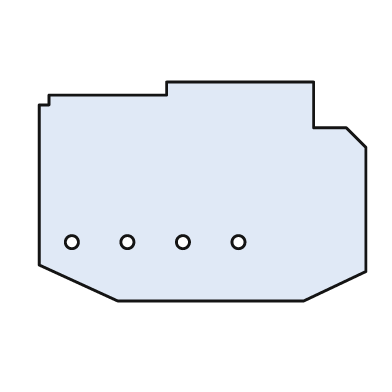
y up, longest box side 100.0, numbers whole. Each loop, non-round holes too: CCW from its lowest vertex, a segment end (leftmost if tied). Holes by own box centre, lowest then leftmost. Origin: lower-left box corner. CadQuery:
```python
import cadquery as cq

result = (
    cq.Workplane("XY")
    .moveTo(24.0, 0.0)
    .lineTo(81.0, 0.0)
    .lineTo(100.0, 9.0)
    .lineTo(100.0, 47.0)
    .lineTo(94.0, 53.0)
    .lineTo(84.0, 53.0)
    .lineTo(84.0, 67.0)
    .lineTo(39.0, 67.0)
    .lineTo(39.0, 63.0)
    .lineTo(3.0, 63.0)
    .lineTo(3.0, 60.0)
    .lineTo(0.0, 60.0)
    .lineTo(0.0, 11.0)
    .close()
    .moveTo(10.0, 18.0)
    .circle(2.0)
    .moveTo(27.0, 18.0)
    .circle(2.0)
    .moveTo(44.0, 18.0)
    .circle(2.0)
    .moveTo(61.0, 18.0)
    .circle(2.0)
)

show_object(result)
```